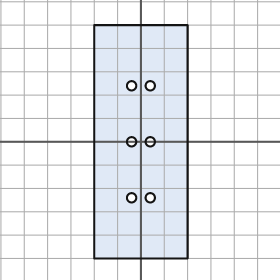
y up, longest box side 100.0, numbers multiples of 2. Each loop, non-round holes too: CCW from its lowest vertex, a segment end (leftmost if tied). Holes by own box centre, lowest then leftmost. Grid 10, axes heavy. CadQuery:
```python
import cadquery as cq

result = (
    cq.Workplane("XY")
    .moveTo(-20.0, -50.0)
    .lineTo(20.0, -50.0)
    .lineTo(20.0, 50.0)
    .lineTo(-20.0, 50.0)
    .close()
    .moveTo(-4.0, -24.0)
    .circle(2.0)
    .moveTo(4.0, -24.0)
    .circle(2.0)
    .moveTo(-4.0, 0.0)
    .circle(2.0)
    .moveTo(4.0, 0.0)
    .circle(2.0)
    .moveTo(-4.0, 24.0)
    .circle(2.0)
    .moveTo(4.0, 24.0)
    .circle(2.0)
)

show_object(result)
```